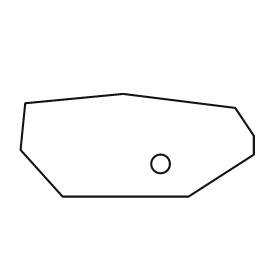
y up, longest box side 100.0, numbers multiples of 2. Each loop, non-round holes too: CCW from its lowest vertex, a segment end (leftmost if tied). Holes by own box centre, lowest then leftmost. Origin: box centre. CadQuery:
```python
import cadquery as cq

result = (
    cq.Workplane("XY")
    .moveTo(-32.0, -22.0)
    .lineTo(22.0, -22.0)
    .lineTo(50.0, -4.0)
    .lineTo(50.0, 4.0)
    .lineTo(42.0, 16.0)
    .lineTo(-6.0, 22.0)
    .lineTo(-48.0, 18.0)
    .lineTo(-50.0, -2.0)
    .close()
    .moveTo(10.0, -8.0)
    .circle(4.0)
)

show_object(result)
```